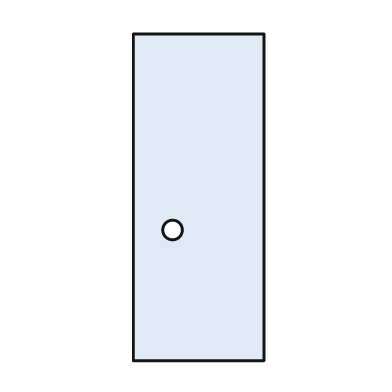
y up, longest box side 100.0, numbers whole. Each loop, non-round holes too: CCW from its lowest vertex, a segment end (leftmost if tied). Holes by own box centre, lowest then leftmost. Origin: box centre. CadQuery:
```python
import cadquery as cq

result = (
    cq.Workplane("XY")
    .moveTo(-20.0, -50.0)
    .lineTo(20.0, -50.0)
    .lineTo(20.0, 50.0)
    .lineTo(-20.0, 50.0)
    .close()
    .moveTo(-8.0, -10.0)
    .circle(3.0)
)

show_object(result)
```